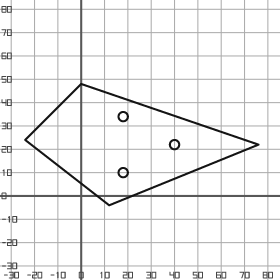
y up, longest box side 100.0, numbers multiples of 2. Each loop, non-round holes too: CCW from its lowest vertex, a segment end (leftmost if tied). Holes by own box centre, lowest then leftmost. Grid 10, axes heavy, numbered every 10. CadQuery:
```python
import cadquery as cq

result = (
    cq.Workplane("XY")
    .moveTo(12.0, -4.0)
    .lineTo(76.0, 22.0)
    .lineTo(0.0, 48.0)
    .lineTo(-24.0, 24.0)
    .close()
    .moveTo(18.0, 10.0)
    .circle(2.0)
    .moveTo(40.0, 22.0)
    .circle(2.0)
    .moveTo(18.0, 34.0)
    .circle(2.0)
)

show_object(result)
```